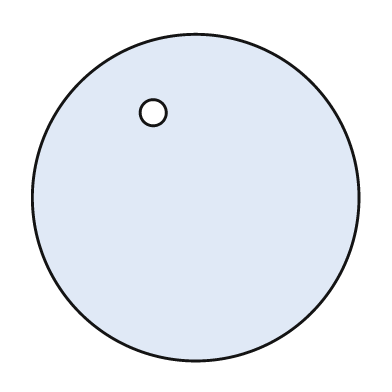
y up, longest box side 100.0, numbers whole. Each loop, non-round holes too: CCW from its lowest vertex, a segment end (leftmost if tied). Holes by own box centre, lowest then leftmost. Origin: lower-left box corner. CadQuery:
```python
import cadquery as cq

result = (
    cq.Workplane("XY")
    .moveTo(50.0, 50.0)
    .circle(50.0)
    .moveTo(37.0, 76.0)
    .circle(4.0)
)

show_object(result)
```